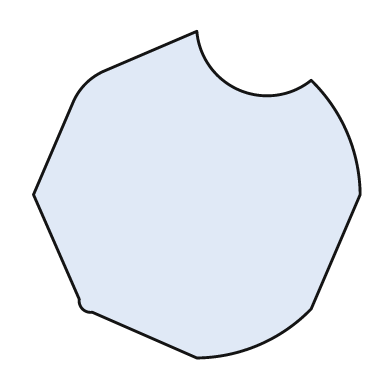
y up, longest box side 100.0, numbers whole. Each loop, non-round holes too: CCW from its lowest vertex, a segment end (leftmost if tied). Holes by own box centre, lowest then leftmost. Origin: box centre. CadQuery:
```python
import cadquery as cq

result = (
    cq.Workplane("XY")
    .moveTo(0.0, -50.0)
    .threePointArc((19.0, -46.0), (35.0, -35.0))
    .lineTo(50.0, 0.0)
    .threePointArc((46.0, 19.0), (35.0, 35.0))
    .threePointArc((13.0, 32.0), (0.0, 50.0))
    .lineTo(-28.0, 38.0)
    .threePointArc((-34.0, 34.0), (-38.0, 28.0))
    .lineTo(-50.0, 0.0)
    .lineTo(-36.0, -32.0)
    .threePointArc((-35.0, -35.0), (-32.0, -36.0))
    .close()
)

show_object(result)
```